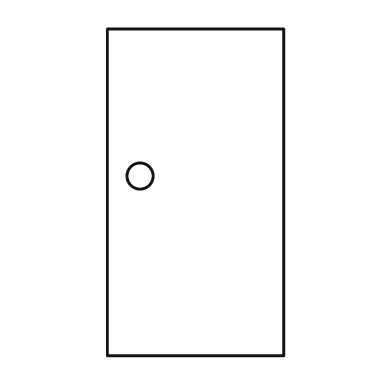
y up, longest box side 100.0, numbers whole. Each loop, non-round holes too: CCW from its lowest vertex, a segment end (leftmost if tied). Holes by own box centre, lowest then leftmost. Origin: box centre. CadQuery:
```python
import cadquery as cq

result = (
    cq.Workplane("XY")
    .moveTo(-27.0, -50.0)
    .lineTo(27.0, -50.0)
    .lineTo(27.0, 50.0)
    .lineTo(-27.0, 50.0)
    .close()
    .moveTo(-17.0, 5.0)
    .circle(4.0)
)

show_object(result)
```